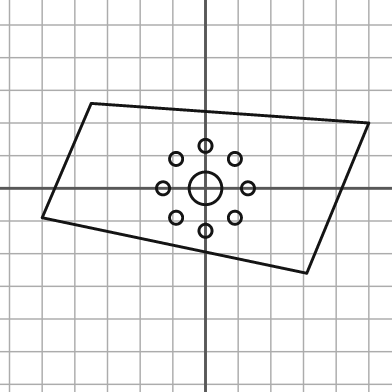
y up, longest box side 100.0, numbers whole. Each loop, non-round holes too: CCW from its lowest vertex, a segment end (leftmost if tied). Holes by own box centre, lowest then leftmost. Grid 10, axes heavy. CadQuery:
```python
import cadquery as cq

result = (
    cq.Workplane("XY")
    .moveTo(31.0, -26.0)
    .lineTo(50.0, 20.0)
    .lineTo(-35.0, 26.0)
    .lineTo(-50.0, -9.0)
    .close()
    .moveTo(0.0, -13.0)
    .circle(2.0)
    .moveTo(-9.0, -9.0)
    .circle(2.0)
    .moveTo(9.0, -9.0)
    .circle(2.0)
    .moveTo(-13.0, 0.0)
    .circle(2.0)
    .moveTo(0.0, 0.0)
    .circle(5.0)
    .moveTo(13.0, 0.0)
    .circle(2.0)
    .moveTo(-9.0, 9.0)
    .circle(2.0)
    .moveTo(9.0, 9.0)
    .circle(2.0)
    .moveTo(0.0, 13.0)
    .circle(2.0)
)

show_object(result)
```